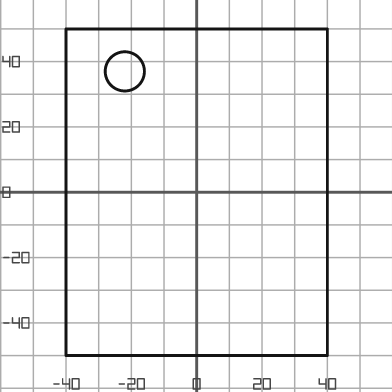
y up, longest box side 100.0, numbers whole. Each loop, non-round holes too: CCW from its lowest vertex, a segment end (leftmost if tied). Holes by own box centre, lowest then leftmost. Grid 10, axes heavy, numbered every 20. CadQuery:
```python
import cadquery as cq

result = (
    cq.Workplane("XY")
    .moveTo(-40.0, -50.0)
    .lineTo(40.0, -50.0)
    .lineTo(40.0, 50.0)
    .lineTo(-40.0, 50.0)
    .close()
    .moveTo(-22.0, 37.0)
    .circle(6.0)
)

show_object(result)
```